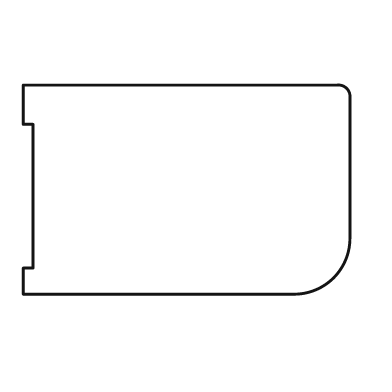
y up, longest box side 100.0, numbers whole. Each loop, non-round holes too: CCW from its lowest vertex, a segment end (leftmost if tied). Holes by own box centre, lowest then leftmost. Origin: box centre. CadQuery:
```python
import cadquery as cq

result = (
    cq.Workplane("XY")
    .moveTo(-50.0, -32.0)
    .lineTo(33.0, -32.0)
    .threePointArc((45.0, -27.0), (50.0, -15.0))
    .lineTo(50.0, 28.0)
    .threePointArc((49.0, 31.0), (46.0, 32.0))
    .lineTo(-50.0, 32.0)
    .lineTo(-50.0, 20.0)
    .lineTo(-47.0, 20.0)
    .lineTo(-47.0, -24.0)
    .lineTo(-50.0, -24.0)
    .close()
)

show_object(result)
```